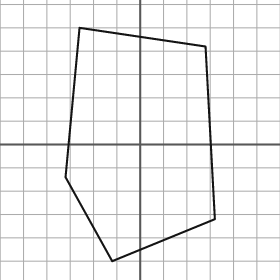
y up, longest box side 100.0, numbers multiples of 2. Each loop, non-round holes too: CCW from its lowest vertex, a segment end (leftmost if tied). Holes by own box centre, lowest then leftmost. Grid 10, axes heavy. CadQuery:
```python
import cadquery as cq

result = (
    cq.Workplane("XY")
    .moveTo(-12.0, -50.0)
    .lineTo(32.0, -32.0)
    .lineTo(28.0, 42.0)
    .lineTo(-26.0, 50.0)
    .lineTo(-32.0, -14.0)
    .close()
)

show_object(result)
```